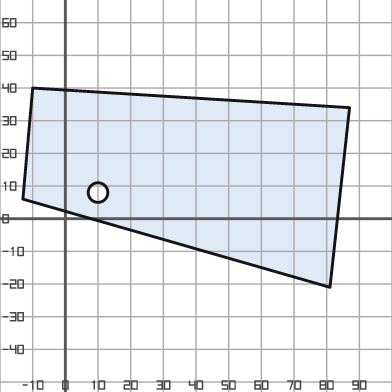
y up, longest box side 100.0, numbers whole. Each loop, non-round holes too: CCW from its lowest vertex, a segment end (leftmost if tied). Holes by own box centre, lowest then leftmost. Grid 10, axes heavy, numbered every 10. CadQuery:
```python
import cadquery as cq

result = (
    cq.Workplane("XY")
    .moveTo(81.0, -21.0)
    .lineTo(87.0, 34.0)
    .lineTo(-10.0, 40.0)
    .lineTo(-13.0, 6.0)
    .close()
    .moveTo(10.0, 8.0)
    .circle(3.0)
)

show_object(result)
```